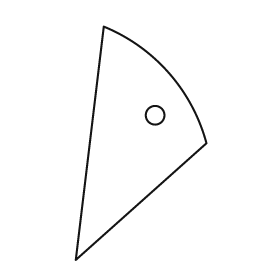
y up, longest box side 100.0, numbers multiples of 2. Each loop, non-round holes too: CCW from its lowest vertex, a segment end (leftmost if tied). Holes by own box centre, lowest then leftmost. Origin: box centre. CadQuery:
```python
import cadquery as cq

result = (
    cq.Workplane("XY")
    .moveTo(-28.0, -50.0)
    .lineTo(28.0, 0.0)
    .threePointArc((12.0, 30.0), (-16.0, 50.0))
    .close()
    .moveTo(6.0, 12.0)
    .circle(4.0)
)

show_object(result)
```